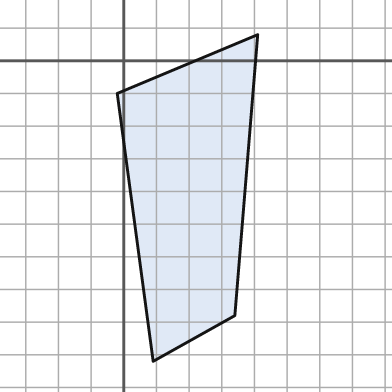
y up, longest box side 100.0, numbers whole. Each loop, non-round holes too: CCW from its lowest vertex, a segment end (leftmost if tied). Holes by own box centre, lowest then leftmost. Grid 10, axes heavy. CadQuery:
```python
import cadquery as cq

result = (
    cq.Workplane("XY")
    .moveTo(9.0, -92.0)
    .lineTo(34.0, -78.0)
    .lineTo(41.0, 8.0)
    .lineTo(-2.0, -10.0)
    .close()
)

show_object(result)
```